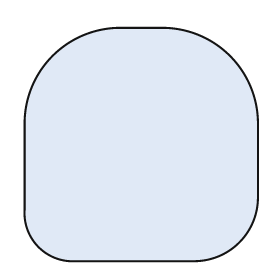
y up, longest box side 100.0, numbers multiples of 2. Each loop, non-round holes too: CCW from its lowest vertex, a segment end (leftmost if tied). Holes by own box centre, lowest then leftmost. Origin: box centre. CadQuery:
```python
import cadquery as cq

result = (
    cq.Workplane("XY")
    .moveTo(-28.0, -50.0)
    .lineTo(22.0, -50.0)
    .threePointArc((42.0, -42.0), (50.0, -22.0))
    .lineTo(50.0, 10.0)
    .threePointArc((38.0, 38.0), (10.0, 50.0))
    .lineTo(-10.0, 50.0)
    .threePointArc((-38.0, 38.0), (-50.0, 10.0))
    .lineTo(-50.0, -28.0)
    .threePointArc((-44.0, -44.0), (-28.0, -50.0))
    .close()
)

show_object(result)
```